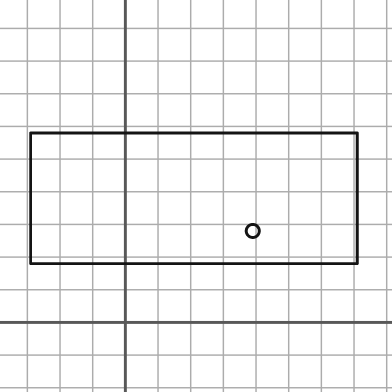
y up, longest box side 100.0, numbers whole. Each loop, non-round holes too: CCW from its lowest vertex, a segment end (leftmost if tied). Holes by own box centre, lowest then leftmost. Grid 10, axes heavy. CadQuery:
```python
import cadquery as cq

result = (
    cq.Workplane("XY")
    .moveTo(-29.0, 18.0)
    .lineTo(71.0, 18.0)
    .lineTo(71.0, 58.0)
    .lineTo(-29.0, 58.0)
    .close()
    .moveTo(39.0, 28.0)
    .circle(2.0)
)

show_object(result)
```